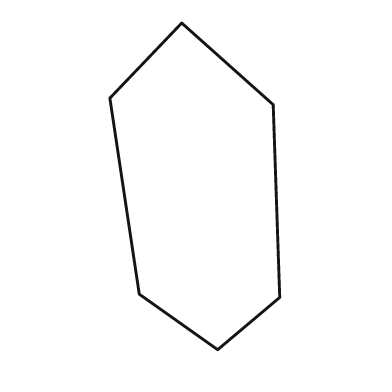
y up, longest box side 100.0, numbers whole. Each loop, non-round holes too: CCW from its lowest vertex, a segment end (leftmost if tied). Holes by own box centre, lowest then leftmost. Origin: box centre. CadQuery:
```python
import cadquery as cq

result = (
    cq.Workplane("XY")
    .moveTo(7.0, -50.0)
    .lineTo(26.0, -34.0)
    .lineTo(24.0, 25.0)
    .lineTo(-4.0, 50.0)
    .lineTo(-26.0, 27.0)
    .lineTo(-17.0, -33.0)
    .close()
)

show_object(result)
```